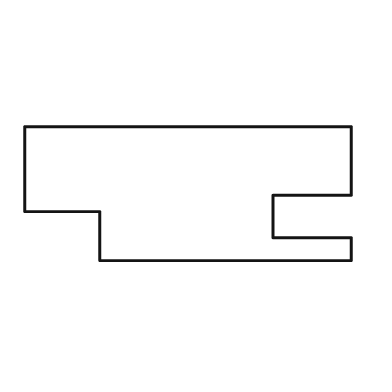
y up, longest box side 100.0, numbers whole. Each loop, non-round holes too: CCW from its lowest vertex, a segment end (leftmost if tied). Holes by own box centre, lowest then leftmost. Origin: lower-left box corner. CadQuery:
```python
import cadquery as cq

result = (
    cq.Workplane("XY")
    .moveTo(23.0, 0.0)
    .lineTo(100.0, 0.0)
    .lineTo(100.0, 7.0)
    .lineTo(76.0, 7.0)
    .lineTo(76.0, 20.0)
    .lineTo(100.0, 20.0)
    .lineTo(100.0, 41.0)
    .lineTo(0.0, 41.0)
    .lineTo(0.0, 15.0)
    .lineTo(23.0, 15.0)
    .close()
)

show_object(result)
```